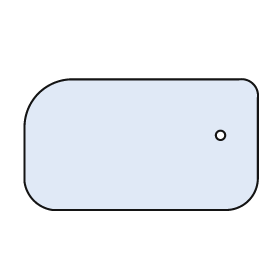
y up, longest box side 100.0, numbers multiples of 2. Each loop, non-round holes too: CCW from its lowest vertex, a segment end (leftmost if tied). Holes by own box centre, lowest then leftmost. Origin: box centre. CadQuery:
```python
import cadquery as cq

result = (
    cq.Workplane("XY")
    .moveTo(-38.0, -28.0)
    .lineTo(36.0, -28.0)
    .threePointArc((46.0, -24.0), (50.0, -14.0))
    .lineTo(50.0, 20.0)
    .threePointArc((48.0, 26.0), (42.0, 28.0))
    .lineTo(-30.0, 28.0)
    .threePointArc((-44.0, 22.0), (-50.0, 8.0))
    .lineTo(-50.0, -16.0)
    .threePointArc((-46.0, -24.0), (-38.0, -28.0))
    .close()
    .moveTo(34.0, 4.0)
    .circle(2.0)
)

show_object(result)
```